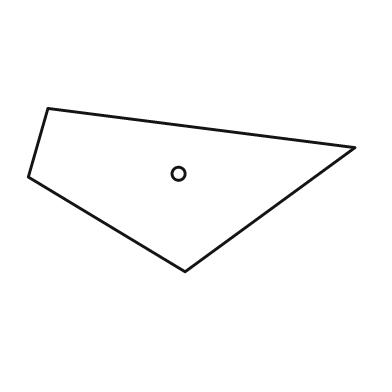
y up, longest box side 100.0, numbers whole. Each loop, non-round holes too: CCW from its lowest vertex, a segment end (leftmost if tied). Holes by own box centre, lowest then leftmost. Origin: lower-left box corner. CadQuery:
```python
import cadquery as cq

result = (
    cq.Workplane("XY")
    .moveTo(48.0, 0.0)
    .lineTo(100.0, 38.0)
    .lineTo(6.0, 50.0)
    .lineTo(0.0, 29.0)
    .close()
    .moveTo(46.0, 30.0)
    .circle(2.0)
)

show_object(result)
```